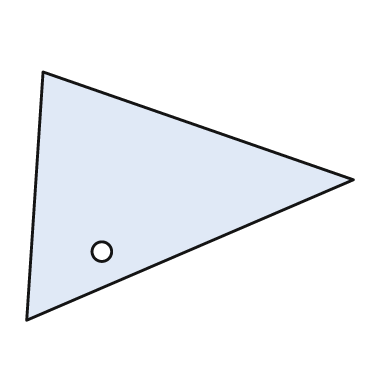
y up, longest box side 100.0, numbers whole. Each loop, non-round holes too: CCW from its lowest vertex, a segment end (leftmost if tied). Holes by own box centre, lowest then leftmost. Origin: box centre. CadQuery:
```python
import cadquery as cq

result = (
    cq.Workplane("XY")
    .moveTo(-50.0, -38.0)
    .lineTo(50.0, 5.0)
    .lineTo(-45.0, 38.0)
    .close()
    .moveTo(-27.0, -17.0)
    .circle(3.0)
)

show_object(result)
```